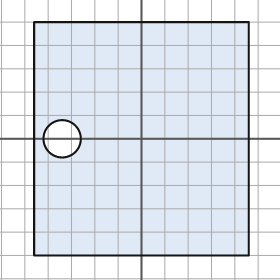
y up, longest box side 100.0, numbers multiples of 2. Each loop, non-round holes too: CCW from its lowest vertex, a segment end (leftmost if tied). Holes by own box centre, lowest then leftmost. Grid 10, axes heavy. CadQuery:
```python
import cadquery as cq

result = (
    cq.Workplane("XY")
    .moveTo(-46.0, -50.0)
    .lineTo(46.0, -50.0)
    .lineTo(46.0, 50.0)
    .lineTo(-46.0, 50.0)
    .close()
    .moveTo(-34.0, 0.0)
    .circle(8.0)
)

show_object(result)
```